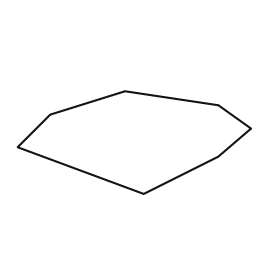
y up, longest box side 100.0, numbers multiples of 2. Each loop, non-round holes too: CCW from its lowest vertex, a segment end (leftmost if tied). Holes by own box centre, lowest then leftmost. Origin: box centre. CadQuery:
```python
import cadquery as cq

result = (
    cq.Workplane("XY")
    .moveTo(4.0, -22.0)
    .lineTo(36.0, -6.0)
    .lineTo(50.0, 6.0)
    .lineTo(36.0, 16.0)
    .lineTo(-4.0, 22.0)
    .lineTo(-36.0, 12.0)
    .lineTo(-50.0, -2.0)
    .close()
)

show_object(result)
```